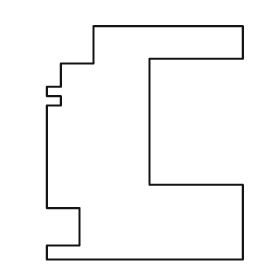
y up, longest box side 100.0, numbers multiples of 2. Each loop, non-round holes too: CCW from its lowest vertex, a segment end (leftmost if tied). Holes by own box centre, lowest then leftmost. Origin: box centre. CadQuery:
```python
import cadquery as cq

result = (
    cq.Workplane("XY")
    .moveTo(-42.0, -50.0)
    .lineTo(42.0, -50.0)
    .lineTo(42.0, -18.0)
    .lineTo(2.0, -18.0)
    .lineTo(2.0, 36.0)
    .lineTo(42.0, 36.0)
    .lineTo(42.0, 50.0)
    .lineTo(-22.0, 50.0)
    .lineTo(-22.0, 34.0)
    .lineTo(-36.0, 34.0)
    .lineTo(-36.0, 24.0)
    .lineTo(-42.0, 24.0)
    .lineTo(-42.0, 20.0)
    .lineTo(-36.0, 20.0)
    .lineTo(-36.0, 16.0)
    .lineTo(-42.0, 16.0)
    .lineTo(-42.0, -28.0)
    .lineTo(-28.0, -28.0)
    .lineTo(-28.0, -44.0)
    .lineTo(-42.0, -44.0)
    .close()
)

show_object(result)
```